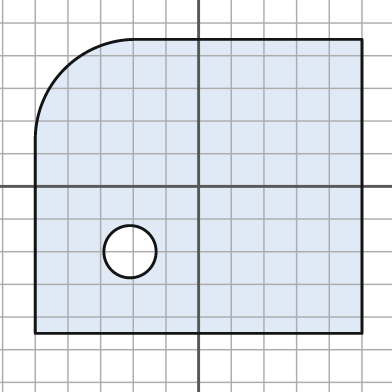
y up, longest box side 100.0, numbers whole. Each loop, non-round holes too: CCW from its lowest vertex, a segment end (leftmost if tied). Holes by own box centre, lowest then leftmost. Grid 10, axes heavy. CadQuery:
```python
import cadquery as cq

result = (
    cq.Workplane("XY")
    .moveTo(-50.0, -45.0)
    .lineTo(50.0, -45.0)
    .lineTo(50.0, 45.0)
    .lineTo(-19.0, 45.0)
    .threePointArc((-41.0, 36.0), (-50.0, 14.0))
    .close()
    .moveTo(-21.0, -20.0)
    .circle(8.0)
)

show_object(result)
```